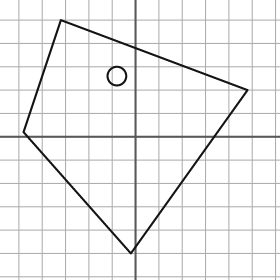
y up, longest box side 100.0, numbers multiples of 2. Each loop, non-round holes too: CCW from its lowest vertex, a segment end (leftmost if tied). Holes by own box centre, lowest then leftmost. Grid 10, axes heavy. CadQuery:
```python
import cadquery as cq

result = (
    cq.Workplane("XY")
    .moveTo(-2.0, -50.0)
    .lineTo(48.0, 20.0)
    .lineTo(-32.0, 50.0)
    .lineTo(-48.0, 2.0)
    .close()
    .moveTo(-8.0, 26.0)
    .circle(4.0)
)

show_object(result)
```